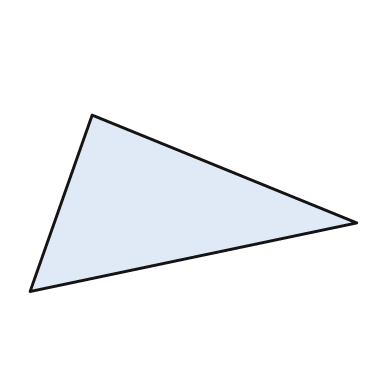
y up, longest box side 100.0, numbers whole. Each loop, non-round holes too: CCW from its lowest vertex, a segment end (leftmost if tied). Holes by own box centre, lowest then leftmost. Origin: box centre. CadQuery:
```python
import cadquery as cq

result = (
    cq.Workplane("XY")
    .moveTo(-50.0, -27.0)
    .lineTo(50.0, -6.0)
    .lineTo(-31.0, 27.0)
    .close()
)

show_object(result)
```